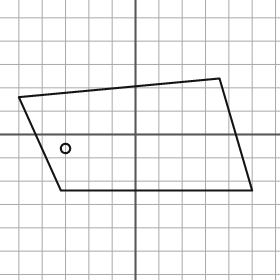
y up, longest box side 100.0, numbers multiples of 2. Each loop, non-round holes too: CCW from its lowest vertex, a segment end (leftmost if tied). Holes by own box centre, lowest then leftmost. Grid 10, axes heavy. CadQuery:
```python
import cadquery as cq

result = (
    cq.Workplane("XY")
    .moveTo(-32.0, -24.0)
    .lineTo(50.0, -24.0)
    .lineTo(36.0, 24.0)
    .lineTo(-50.0, 16.0)
    .close()
    .moveTo(-30.0, -6.0)
    .circle(2.0)
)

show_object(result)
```